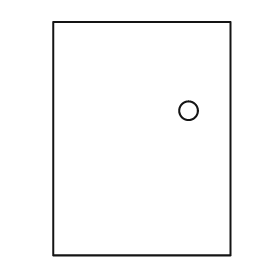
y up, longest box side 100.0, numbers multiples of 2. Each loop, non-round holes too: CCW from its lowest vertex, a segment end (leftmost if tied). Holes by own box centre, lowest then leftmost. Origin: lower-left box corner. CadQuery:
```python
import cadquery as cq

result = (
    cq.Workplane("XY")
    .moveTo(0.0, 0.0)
    .lineTo(76.0, 0.0)
    .lineTo(76.0, 100.0)
    .lineTo(0.0, 100.0)
    .close()
    .moveTo(58.0, 62.0)
    .circle(4.0)
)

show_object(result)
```